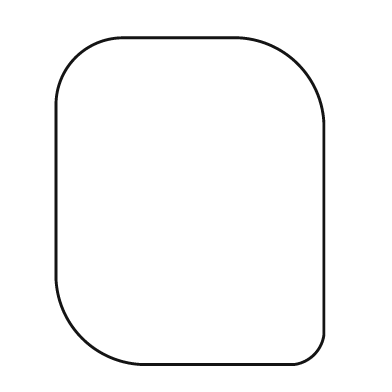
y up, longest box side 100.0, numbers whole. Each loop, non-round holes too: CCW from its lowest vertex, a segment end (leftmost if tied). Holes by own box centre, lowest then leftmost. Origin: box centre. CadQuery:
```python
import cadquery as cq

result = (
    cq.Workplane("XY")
    .moveTo(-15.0, -50.0)
    .lineTo(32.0, -50.0)
    .threePointArc((38.0, -47.0), (41.0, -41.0))
    .lineTo(41.0, 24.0)
    .threePointArc((33.0, 42.0), (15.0, 50.0))
    .lineTo(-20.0, 50.0)
    .threePointArc((-35.0, 44.0), (-41.0, 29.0))
    .lineTo(-41.0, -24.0)
    .threePointArc((-33.0, -42.0), (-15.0, -50.0))
    .close()
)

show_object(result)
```